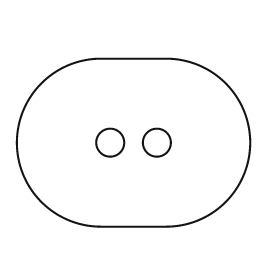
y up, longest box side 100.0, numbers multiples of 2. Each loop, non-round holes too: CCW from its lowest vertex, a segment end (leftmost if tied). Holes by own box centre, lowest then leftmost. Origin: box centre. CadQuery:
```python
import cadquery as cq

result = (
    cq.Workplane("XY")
    .moveTo(-14.0, -36.0)
    .lineTo(14.0, -36.0)
    .threePointArc((50.0, 0.0), (14.0, 36.0))
    .lineTo(-14.0, 36.0)
    .threePointArc((-50.0, 0.0), (-14.0, -36.0))
    .close()
    .moveTo(-10.0, 0.0)
    .circle(6.0)
    .moveTo(10.0, 0.0)
    .circle(6.0)
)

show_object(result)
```